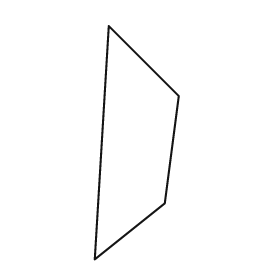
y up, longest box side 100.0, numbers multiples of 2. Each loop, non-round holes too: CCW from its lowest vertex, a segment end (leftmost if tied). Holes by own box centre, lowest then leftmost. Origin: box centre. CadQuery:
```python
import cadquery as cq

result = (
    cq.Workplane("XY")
    .moveTo(-18.0, -50.0)
    .lineTo(12.0, -26.0)
    .lineTo(18.0, 20.0)
    .lineTo(-12.0, 50.0)
    .close()
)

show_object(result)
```